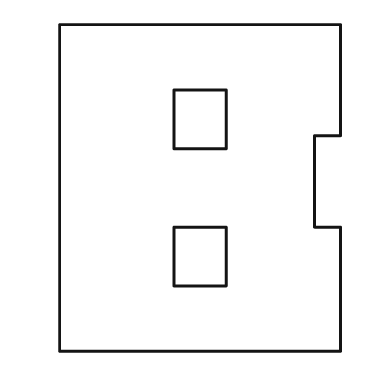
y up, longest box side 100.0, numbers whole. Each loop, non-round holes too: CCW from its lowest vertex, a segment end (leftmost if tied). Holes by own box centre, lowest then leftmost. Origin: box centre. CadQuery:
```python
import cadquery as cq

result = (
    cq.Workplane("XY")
    .moveTo(-43.0, -50.0)
    .lineTo(43.0, -50.0)
    .lineTo(43.0, -12.0)
    .lineTo(35.0, -12.0)
    .lineTo(35.0, 16.0)
    .lineTo(43.0, 16.0)
    .lineTo(43.0, 50.0)
    .lineTo(-43.0, 50.0)
    .close()
    .moveTo(-8.0, -30.0)
    .lineTo(8.0, -30.0)
    .lineTo(8.0, -12.0)
    .lineTo(-8.0, -12.0)
    .close()
    .moveTo(-8.0, 12.0)
    .lineTo(8.0, 12.0)
    .lineTo(8.0, 30.0)
    .lineTo(-8.0, 30.0)
    .close()
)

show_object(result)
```